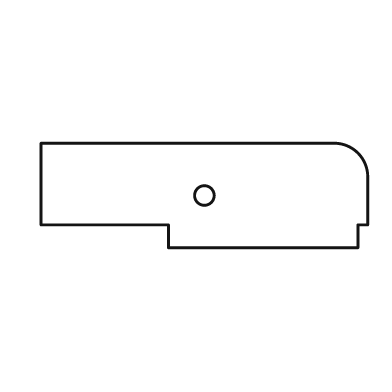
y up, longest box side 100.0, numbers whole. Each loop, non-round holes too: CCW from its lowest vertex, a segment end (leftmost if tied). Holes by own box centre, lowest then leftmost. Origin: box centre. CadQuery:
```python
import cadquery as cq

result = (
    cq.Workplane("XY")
    .moveTo(-11.0, -16.0)
    .lineTo(47.0, -16.0)
    .lineTo(47.0, -9.0)
    .lineTo(50.0, -9.0)
    .lineTo(50.0, 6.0)
    .threePointArc((47.0, 13.0), (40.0, 16.0))
    .lineTo(-50.0, 16.0)
    .lineTo(-50.0, -9.0)
    .lineTo(-11.0, -9.0)
    .close()
    .moveTo(0.0, 0.0)
    .circle(3.0)
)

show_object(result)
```